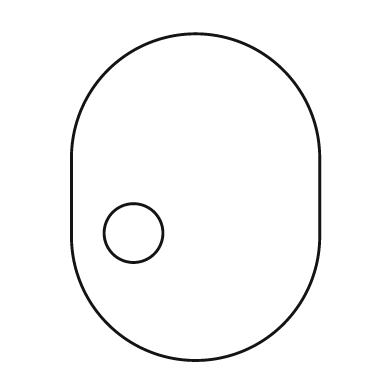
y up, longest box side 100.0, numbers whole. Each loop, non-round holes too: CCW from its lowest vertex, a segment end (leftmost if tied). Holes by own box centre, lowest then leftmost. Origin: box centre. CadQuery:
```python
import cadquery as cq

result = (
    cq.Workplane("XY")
    .moveTo(-38.0, -12.0)
    .threePointArc((0.0, -50.0), (38.0, -12.0))
    .lineTo(38.0, 12.0)
    .threePointArc((0.0, 50.0), (-38.0, 12.0))
    .close()
    .moveTo(-19.0, -11.0)
    .circle(9.0)
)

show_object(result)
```